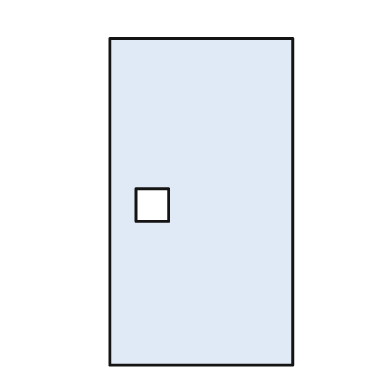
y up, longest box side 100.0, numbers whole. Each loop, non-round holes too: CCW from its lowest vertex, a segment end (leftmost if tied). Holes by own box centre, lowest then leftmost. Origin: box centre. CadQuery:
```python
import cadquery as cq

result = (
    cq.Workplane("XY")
    .moveTo(-28.0, -50.0)
    .lineTo(28.0, -50.0)
    .lineTo(28.0, 50.0)
    .lineTo(-28.0, 50.0)
    .close()
    .moveTo(-20.0, -6.0)
    .lineTo(-10.0, -6.0)
    .lineTo(-10.0, 4.0)
    .lineTo(-20.0, 4.0)
    .close()
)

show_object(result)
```